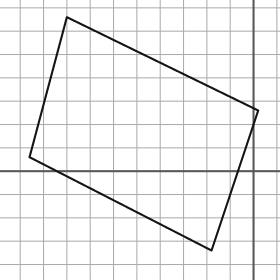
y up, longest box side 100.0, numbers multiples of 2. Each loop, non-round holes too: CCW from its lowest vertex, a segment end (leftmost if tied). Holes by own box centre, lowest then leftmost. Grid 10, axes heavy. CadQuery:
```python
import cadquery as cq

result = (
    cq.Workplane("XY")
    .moveTo(-18.0, -34.0)
    .lineTo(2.0, 26.0)
    .lineTo(-80.0, 66.0)
    .lineTo(-96.0, 6.0)
    .close()
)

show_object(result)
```